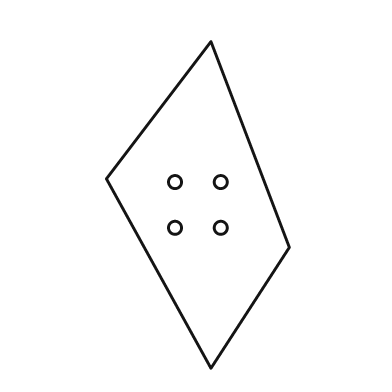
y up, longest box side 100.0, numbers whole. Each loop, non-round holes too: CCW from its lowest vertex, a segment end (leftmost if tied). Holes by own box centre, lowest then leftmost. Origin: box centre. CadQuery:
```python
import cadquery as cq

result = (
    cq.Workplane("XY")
    .moveTo(4.0, -50.0)
    .lineTo(28.0, -13.0)
    .lineTo(4.0, 50.0)
    .lineTo(-28.0, 8.0)
    .close()
    .moveTo(-7.0, -7.0)
    .circle(2.0)
    .moveTo(7.0, -7.0)
    .circle(2.0)
    .moveTo(-7.0, 7.0)
    .circle(2.0)
    .moveTo(7.0, 7.0)
    .circle(2.0)
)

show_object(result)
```